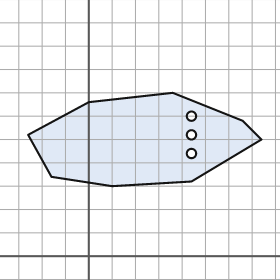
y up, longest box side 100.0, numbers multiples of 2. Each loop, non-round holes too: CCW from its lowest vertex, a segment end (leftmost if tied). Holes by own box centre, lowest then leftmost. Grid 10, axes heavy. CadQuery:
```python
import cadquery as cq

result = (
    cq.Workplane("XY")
    .moveTo(10.0, 30.0)
    .lineTo(44.0, 32.0)
    .lineTo(74.0, 50.0)
    .lineTo(66.0, 58.0)
    .lineTo(36.0, 70.0)
    .lineTo(0.0, 66.0)
    .lineTo(-26.0, 52.0)
    .lineTo(-16.0, 34.0)
    .close()
    .moveTo(44.0, 44.0)
    .circle(2.0)
    .moveTo(44.0, 52.0)
    .circle(2.0)
    .moveTo(44.0, 60.0)
    .circle(2.0)
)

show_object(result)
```